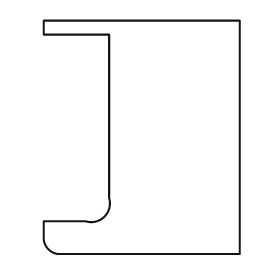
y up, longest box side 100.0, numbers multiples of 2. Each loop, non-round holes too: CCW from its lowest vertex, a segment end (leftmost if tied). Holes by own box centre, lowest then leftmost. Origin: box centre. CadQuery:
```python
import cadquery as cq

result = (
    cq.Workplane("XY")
    .moveTo(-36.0, -50.0)
    .lineTo(42.0, -50.0)
    .lineTo(42.0, 50.0)
    .lineTo(-42.0, 50.0)
    .lineTo(-42.0, 44.0)
    .lineTo(-14.0, 44.0)
    .lineTo(-14.0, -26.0)
    .threePointArc((-16.0, -34.0), (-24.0, -36.0))
    .lineTo(-42.0, -36.0)
    .lineTo(-42.0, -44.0)
    .threePointArc((-40.0, -48.0), (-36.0, -50.0))
    .close()
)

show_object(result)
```